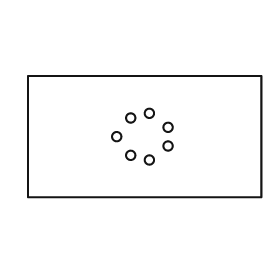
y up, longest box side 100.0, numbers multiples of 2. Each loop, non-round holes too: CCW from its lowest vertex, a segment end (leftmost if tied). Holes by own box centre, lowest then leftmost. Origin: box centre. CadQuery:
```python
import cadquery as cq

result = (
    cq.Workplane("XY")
    .moveTo(-50.0, -26.0)
    .lineTo(50.0, -26.0)
    .lineTo(50.0, 26.0)
    .lineTo(-50.0, 26.0)
    .close()
    .moveTo(2.0, -10.0)
    .circle(2.0)
    .moveTo(-6.0, -8.0)
    .circle(2.0)
    .moveTo(10.0, -4.0)
    .circle(2.0)
    .moveTo(-12.0, 0.0)
    .circle(2.0)
    .moveTo(10.0, 4.0)
    .circle(2.0)
    .moveTo(-6.0, 8.0)
    .circle(2.0)
    .moveTo(2.0, 10.0)
    .circle(2.0)
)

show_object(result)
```